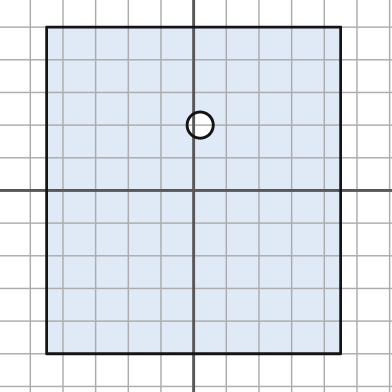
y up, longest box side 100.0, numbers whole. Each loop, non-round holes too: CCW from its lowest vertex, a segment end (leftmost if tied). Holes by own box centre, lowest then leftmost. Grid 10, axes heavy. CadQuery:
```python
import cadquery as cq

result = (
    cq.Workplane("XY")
    .moveTo(-45.0, -50.0)
    .lineTo(45.0, -50.0)
    .lineTo(45.0, 50.0)
    .lineTo(-45.0, 50.0)
    .close()
    .moveTo(2.0, 20.0)
    .circle(4.0)
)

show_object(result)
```